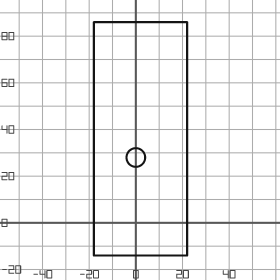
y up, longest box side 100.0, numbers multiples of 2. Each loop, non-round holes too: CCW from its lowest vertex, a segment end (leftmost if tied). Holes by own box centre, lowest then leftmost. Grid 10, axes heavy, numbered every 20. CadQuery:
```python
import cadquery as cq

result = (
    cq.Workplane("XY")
    .moveTo(-18.0, -14.0)
    .lineTo(22.0, -14.0)
    .lineTo(22.0, 86.0)
    .lineTo(-18.0, 86.0)
    .close()
    .moveTo(0.0, 28.0)
    .circle(4.0)
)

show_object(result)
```